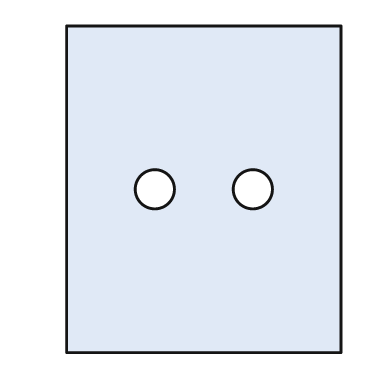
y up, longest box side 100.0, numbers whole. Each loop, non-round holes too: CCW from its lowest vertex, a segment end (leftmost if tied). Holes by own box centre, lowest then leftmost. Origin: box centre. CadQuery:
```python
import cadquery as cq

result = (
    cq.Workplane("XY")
    .moveTo(-42.0, -50.0)
    .lineTo(42.0, -50.0)
    .lineTo(42.0, 50.0)
    .lineTo(-42.0, 50.0)
    .close()
    .moveTo(-15.0, 0.0)
    .circle(6.0)
    .moveTo(15.0, 0.0)
    .circle(6.0)
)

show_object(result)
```